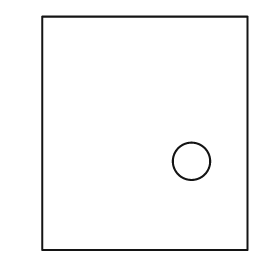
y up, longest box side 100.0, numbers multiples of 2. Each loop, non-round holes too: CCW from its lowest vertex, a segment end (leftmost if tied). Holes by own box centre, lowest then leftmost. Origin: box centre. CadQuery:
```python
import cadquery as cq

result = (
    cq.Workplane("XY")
    .moveTo(-44.0, -50.0)
    .lineTo(44.0, -50.0)
    .lineTo(44.0, 50.0)
    .lineTo(-44.0, 50.0)
    .close()
    .moveTo(20.0, -12.0)
    .circle(8.0)
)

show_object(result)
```